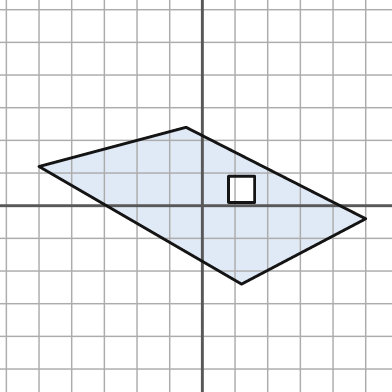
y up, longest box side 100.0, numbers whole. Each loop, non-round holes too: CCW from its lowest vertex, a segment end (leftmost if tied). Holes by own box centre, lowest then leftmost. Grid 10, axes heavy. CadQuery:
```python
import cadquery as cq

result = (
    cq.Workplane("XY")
    .moveTo(12.0, -24.0)
    .lineTo(50.0, -4.0)
    .lineTo(-5.0, 24.0)
    .lineTo(-50.0, 12.0)
    .close()
    .moveTo(8.0, 1.0)
    .lineTo(16.0, 1.0)
    .lineTo(16.0, 9.0)
    .lineTo(8.0, 9.0)
    .close()
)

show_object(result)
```